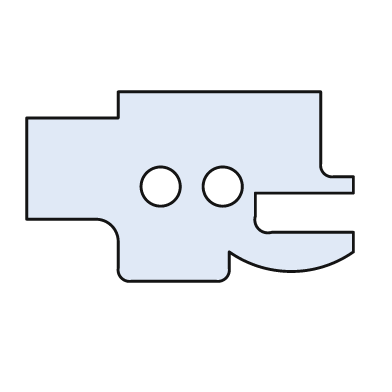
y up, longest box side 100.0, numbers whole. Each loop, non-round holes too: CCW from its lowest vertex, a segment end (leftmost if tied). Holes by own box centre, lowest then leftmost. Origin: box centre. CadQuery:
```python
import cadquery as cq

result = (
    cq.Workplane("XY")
    .moveTo(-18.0, -29.0)
    .lineTo(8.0, -29.0)
    .threePointArc((11.0, -28.0), (12.0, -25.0))
    .lineTo(12.0, -20.0)
    .threePointArc((31.0, -26.0), (50.0, -20.0))
    .lineTo(50.0, -14.0)
    .lineTo(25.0, -14.0)
    .threePointArc((21.0, -13.0), (20.0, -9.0))
    .lineTo(20.0, -2.0)
    .lineTo(50.0, -2.0)
    .lineTo(50.0, 3.0)
    .lineTo(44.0, 3.0)
    .threePointArc((41.0, 4.0), (40.0, 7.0))
    .lineTo(40.0, 29.0)
    .lineTo(-22.0, 29.0)
    .lineTo(-22.0, 21.0)
    .lineTo(-50.0, 21.0)
    .lineTo(-50.0, -10.0)
    .lineTo(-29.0, -10.0)
    .threePointArc((-24.0, -12.0), (-22.0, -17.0))
    .lineTo(-22.0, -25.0)
    .threePointArc((-21.0, -28.0), (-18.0, -29.0))
    .close()
    .moveTo(-9.0, 0.0)
    .circle(6.0)
    .moveTo(10.0, 0.0)
    .circle(6.0)
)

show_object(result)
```